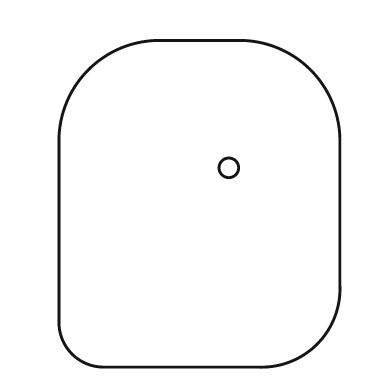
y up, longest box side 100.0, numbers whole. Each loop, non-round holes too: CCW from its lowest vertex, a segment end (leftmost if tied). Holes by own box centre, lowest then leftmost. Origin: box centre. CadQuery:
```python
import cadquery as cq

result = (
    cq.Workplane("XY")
    .moveTo(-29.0, -50.0)
    .lineTo(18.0, -50.0)
    .threePointArc((36.0, -43.0), (43.0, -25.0))
    .lineTo(43.0, 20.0)
    .threePointArc((34.0, 41.0), (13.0, 50.0))
    .lineTo(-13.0, 50.0)
    .threePointArc((-34.0, 41.0), (-43.0, 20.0))
    .lineTo(-43.0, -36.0)
    .threePointArc((-39.0, -46.0), (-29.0, -50.0))
    .close()
    .moveTo(9.0, 11.0)
    .circle(3.0)
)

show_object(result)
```